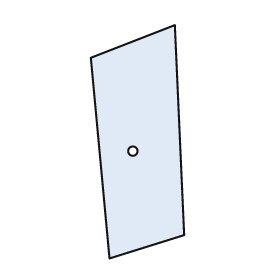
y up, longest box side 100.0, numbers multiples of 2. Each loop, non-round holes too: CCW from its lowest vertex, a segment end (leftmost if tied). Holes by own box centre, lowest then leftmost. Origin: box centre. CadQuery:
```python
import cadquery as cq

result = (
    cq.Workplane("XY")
    .moveTo(-12.0, -50.0)
    .lineTo(20.0, -40.0)
    .lineTo(16.0, 50.0)
    .lineTo(-20.0, 36.0)
    .close()
    .moveTo(-2.0, -4.0)
    .circle(2.0)
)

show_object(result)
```